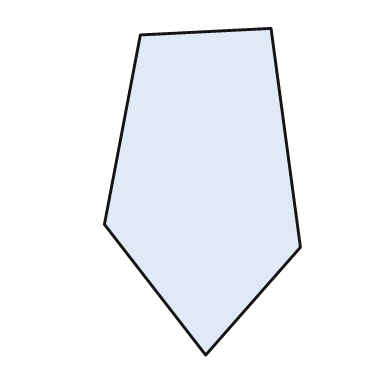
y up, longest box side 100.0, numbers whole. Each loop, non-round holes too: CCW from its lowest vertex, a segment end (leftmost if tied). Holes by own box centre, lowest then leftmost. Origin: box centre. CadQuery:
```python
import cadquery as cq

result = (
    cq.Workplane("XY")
    .moveTo(1.0, -50.0)
    .lineTo(30.0, -17.0)
    .lineTo(21.0, 50.0)
    .lineTo(-19.0, 48.0)
    .lineTo(-30.0, -10.0)
    .close()
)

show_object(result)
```